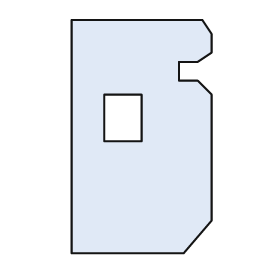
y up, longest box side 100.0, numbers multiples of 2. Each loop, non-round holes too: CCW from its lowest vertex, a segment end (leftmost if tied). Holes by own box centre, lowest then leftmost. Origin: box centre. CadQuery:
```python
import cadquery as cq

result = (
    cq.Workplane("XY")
    .moveTo(-30.0, -50.0)
    .lineTo(18.0, -50.0)
    .lineTo(30.0, -36.0)
    .lineTo(30.0, 18.0)
    .lineTo(24.0, 24.0)
    .lineTo(16.0, 24.0)
    .lineTo(16.0, 32.0)
    .lineTo(24.0, 32.0)
    .lineTo(30.0, 36.0)
    .lineTo(30.0, 44.0)
    .lineTo(26.0, 50.0)
    .lineTo(-30.0, 50.0)
    .close()
    .moveTo(-16.0, -2.0)
    .lineTo(0.0, -2.0)
    .lineTo(0.0, 18.0)
    .lineTo(-16.0, 18.0)
    .close()
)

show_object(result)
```